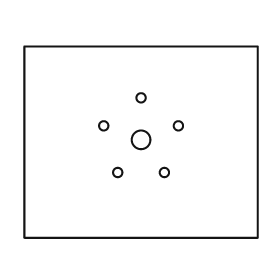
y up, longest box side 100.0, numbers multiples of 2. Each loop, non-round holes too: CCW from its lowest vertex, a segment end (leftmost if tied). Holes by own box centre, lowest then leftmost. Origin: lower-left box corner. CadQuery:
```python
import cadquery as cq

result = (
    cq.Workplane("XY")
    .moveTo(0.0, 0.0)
    .lineTo(100.0, 0.0)
    .lineTo(100.0, 82.0)
    .lineTo(0.0, 82.0)
    .close()
    .moveTo(40.0, 28.0)
    .circle(2.0)
    .moveTo(60.0, 28.0)
    .circle(2.0)
    .moveTo(50.0, 42.0)
    .circle(4.0)
    .moveTo(34.0, 48.0)
    .circle(2.0)
    .moveTo(66.0, 48.0)
    .circle(2.0)
    .moveTo(50.0, 60.0)
    .circle(2.0)
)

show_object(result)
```